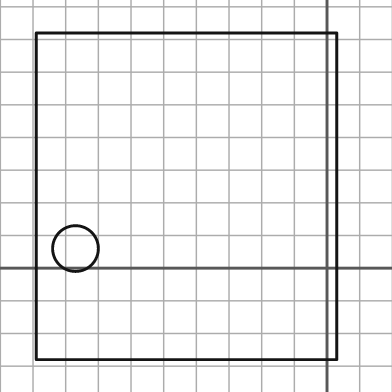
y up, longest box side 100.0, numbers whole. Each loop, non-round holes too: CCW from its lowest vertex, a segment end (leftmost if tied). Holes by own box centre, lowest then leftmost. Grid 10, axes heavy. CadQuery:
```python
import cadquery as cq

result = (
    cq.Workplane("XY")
    .moveTo(-89.0, -28.0)
    .lineTo(3.0, -28.0)
    .lineTo(3.0, 72.0)
    .lineTo(-89.0, 72.0)
    .close()
    .moveTo(-77.0, 6.0)
    .circle(7.0)
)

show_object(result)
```